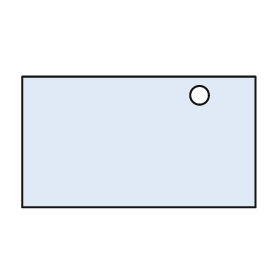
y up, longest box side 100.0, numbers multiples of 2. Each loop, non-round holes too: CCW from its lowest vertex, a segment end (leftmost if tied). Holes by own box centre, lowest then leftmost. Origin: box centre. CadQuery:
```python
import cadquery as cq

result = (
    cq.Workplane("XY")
    .moveTo(-50.0, -28.0)
    .lineTo(50.0, -28.0)
    .lineTo(50.0, 28.0)
    .lineTo(-50.0, 28.0)
    .close()
    .moveTo(26.0, 20.0)
    .circle(4.0)
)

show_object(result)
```